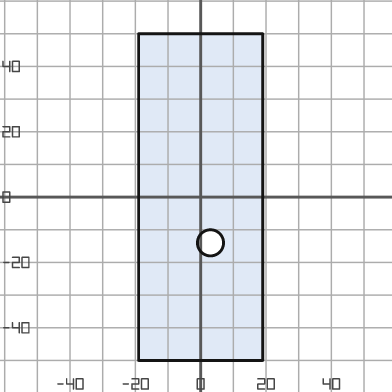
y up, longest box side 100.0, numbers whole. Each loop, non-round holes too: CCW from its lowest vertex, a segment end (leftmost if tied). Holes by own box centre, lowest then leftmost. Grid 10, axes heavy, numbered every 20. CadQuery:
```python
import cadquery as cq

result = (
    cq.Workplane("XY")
    .moveTo(-19.0, -50.0)
    .lineTo(19.0, -50.0)
    .lineTo(19.0, 50.0)
    .lineTo(-19.0, 50.0)
    .close()
    .moveTo(3.0, -14.0)
    .circle(4.0)
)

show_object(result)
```